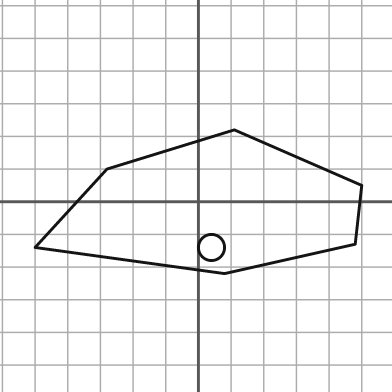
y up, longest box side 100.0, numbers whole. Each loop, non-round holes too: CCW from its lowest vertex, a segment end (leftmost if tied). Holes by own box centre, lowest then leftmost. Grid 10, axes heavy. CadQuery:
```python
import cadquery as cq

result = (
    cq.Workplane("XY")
    .moveTo(8.0, -22.0)
    .lineTo(48.0, -13.0)
    .lineTo(50.0, 5.0)
    .lineTo(11.0, 22.0)
    .lineTo(-28.0, 10.0)
    .lineTo(-50.0, -14.0)
    .close()
    .moveTo(4.0, -14.0)
    .circle(4.0)
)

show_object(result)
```